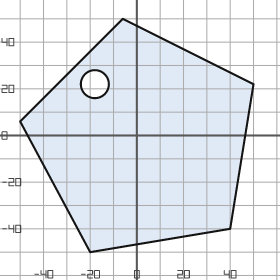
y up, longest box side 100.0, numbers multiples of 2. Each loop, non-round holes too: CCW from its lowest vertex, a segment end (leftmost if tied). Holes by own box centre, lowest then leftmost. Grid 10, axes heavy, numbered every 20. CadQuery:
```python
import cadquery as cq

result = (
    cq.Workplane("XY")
    .moveTo(-20.0, -50.0)
    .lineTo(40.0, -40.0)
    .lineTo(50.0, 22.0)
    .lineTo(-6.0, 50.0)
    .lineTo(-50.0, 6.0)
    .close()
    .moveTo(-18.0, 22.0)
    .circle(6.0)
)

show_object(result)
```